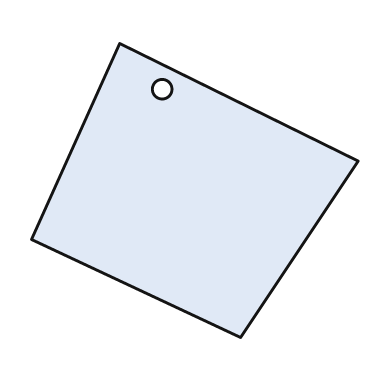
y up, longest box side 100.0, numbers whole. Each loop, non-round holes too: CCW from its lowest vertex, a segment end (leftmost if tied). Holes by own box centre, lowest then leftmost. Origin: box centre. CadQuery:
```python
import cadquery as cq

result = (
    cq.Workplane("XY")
    .moveTo(14.0, -45.0)
    .lineTo(50.0, 9.0)
    .lineTo(-23.0, 45.0)
    .lineTo(-50.0, -15.0)
    .close()
    .moveTo(-10.0, 31.0)
    .circle(3.0)
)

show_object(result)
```